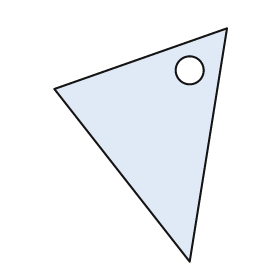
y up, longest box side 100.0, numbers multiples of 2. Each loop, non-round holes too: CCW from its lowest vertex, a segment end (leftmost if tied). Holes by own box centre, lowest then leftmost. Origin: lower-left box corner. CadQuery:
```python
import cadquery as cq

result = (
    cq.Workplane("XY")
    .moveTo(58.0, 0.0)
    .lineTo(74.0, 100.0)
    .lineTo(0.0, 74.0)
    .close()
    .moveTo(58.0, 82.0)
    .circle(6.0)
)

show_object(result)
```